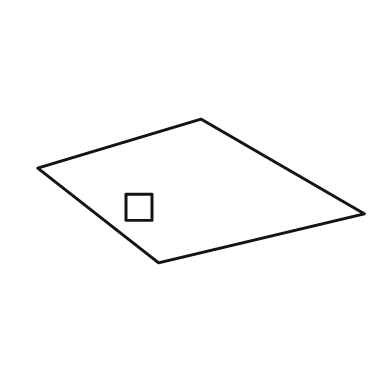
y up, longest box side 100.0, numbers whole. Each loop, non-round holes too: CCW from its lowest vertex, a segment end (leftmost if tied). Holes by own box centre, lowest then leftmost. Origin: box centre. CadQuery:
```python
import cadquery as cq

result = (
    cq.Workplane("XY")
    .moveTo(-13.0, -22.0)
    .lineTo(50.0, -7.0)
    .lineTo(0.0, 22.0)
    .lineTo(-50.0, 7.0)
    .close()
    .moveTo(-23.0, -9.0)
    .lineTo(-15.0, -9.0)
    .lineTo(-15.0, -1.0)
    .lineTo(-23.0, -1.0)
    .close()
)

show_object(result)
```